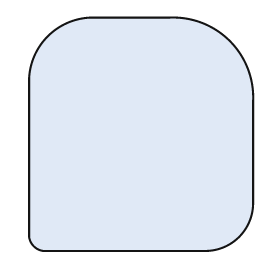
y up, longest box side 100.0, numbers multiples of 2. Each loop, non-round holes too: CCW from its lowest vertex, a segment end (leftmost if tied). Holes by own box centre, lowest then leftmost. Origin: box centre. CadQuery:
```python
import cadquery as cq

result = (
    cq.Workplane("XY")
    .moveTo(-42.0, -50.0)
    .lineTo(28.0, -50.0)
    .threePointArc((42.0, -44.0), (48.0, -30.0))
    .lineTo(48.0, 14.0)
    .threePointArc((38.0, 40.0), (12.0, 50.0))
    .lineTo(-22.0, 50.0)
    .threePointArc((-40.0, 42.0), (-48.0, 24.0))
    .lineTo(-48.0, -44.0)
    .threePointArc((-46.0, -48.0), (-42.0, -50.0))
    .close()
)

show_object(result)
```